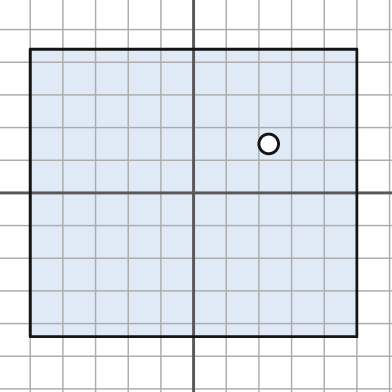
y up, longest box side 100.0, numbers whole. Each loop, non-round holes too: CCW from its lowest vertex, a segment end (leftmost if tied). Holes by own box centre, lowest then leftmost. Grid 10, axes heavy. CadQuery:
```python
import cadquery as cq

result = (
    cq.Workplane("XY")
    .moveTo(-50.0, -44.0)
    .lineTo(50.0, -44.0)
    .lineTo(50.0, 44.0)
    .lineTo(-50.0, 44.0)
    .close()
    .moveTo(23.0, 15.0)
    .circle(3.0)
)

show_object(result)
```